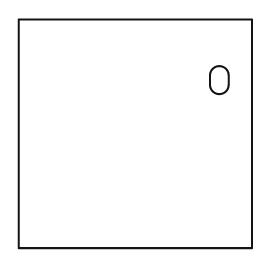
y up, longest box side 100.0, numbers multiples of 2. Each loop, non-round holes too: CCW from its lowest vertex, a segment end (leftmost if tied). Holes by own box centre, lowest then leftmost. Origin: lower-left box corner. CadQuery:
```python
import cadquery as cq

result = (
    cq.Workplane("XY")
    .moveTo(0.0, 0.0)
    .lineTo(100.0, 0.0)
    .lineTo(100.0, 98.0)
    .lineTo(0.0, 98.0)
    .close()
    .moveTo(82.0, 70.0)
    .threePointArc((86.0, 66.0), (90.0, 70.0))
    .lineTo(90.0, 74.0)
    .threePointArc((86.0, 78.0), (82.0, 74.0))
    .close()
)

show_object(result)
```